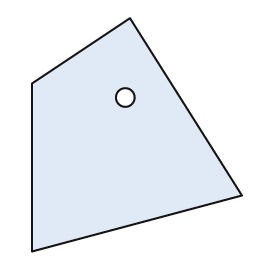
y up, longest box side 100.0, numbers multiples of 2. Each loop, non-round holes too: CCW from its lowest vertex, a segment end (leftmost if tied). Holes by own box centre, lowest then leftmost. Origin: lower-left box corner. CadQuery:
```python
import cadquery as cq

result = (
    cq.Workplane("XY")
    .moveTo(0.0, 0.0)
    .lineTo(90.0, 24.0)
    .lineTo(42.0, 100.0)
    .lineTo(0.0, 72.0)
    .close()
    .moveTo(40.0, 66.0)
    .circle(4.0)
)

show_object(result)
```